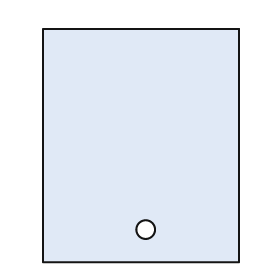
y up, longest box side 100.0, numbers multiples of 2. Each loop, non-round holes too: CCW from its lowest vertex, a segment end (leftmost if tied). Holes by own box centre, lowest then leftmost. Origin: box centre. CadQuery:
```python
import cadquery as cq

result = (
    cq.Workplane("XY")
    .moveTo(-42.0, -50.0)
    .lineTo(42.0, -50.0)
    .lineTo(42.0, 50.0)
    .lineTo(-42.0, 50.0)
    .close()
    .moveTo(2.0, -36.0)
    .circle(4.0)
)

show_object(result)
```